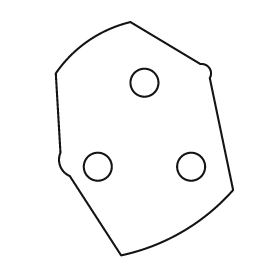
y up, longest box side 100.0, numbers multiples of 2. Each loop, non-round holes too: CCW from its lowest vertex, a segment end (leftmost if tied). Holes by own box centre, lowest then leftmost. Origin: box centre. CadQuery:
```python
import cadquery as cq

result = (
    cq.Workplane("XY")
    .moveTo(-10.0, -50.0)
    .threePointArc((16.0, -40.0), (38.0, -22.0))
    .lineTo(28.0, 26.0)
    .threePointArc((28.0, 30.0), (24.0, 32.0))
    .lineTo(-6.0, 50.0)
    .threePointArc((-24.0, 42.0), (-38.0, 28.0))
    .lineTo(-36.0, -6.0)
    .threePointArc((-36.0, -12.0), (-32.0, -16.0))
    .close()
    .moveTo(-20.0, -12.0)
    .circle(6.0)
    .moveTo(20.0, -12.0)
    .circle(6.0)
    .moveTo(0.0, 24.0)
    .circle(6.0)
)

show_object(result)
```